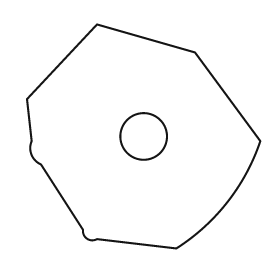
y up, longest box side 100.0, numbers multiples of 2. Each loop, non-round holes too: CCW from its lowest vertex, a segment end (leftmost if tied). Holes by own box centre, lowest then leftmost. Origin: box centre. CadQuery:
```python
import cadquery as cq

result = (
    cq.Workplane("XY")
    .moveTo(14.0, -48.0)
    .threePointArc((36.0, -28.0), (50.0, -2.0))
    .lineTo(22.0, 36.0)
    .lineTo(-20.0, 48.0)
    .lineTo(-50.0, 16.0)
    .lineTo(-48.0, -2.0)
    .threePointArc((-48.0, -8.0), (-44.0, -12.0))
    .lineTo(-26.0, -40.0)
    .threePointArc((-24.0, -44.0), (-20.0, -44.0))
    .close()
    .moveTo(0.0, 0.0)
    .circle(10.0)
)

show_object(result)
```